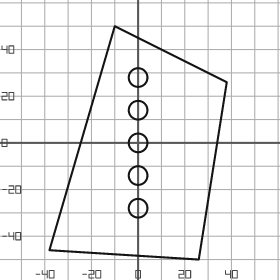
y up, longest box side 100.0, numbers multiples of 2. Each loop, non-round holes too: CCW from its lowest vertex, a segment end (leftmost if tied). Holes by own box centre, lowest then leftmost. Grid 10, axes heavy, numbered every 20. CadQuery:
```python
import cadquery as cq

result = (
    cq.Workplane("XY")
    .moveTo(26.0, -50.0)
    .lineTo(38.0, 26.0)
    .lineTo(-10.0, 50.0)
    .lineTo(-38.0, -46.0)
    .close()
    .moveTo(0.0, -28.0)
    .circle(4.0)
    .moveTo(0.0, -14.0)
    .circle(4.0)
    .moveTo(0.0, 0.0)
    .circle(4.0)
    .moveTo(0.0, 14.0)
    .circle(4.0)
    .moveTo(0.0, 28.0)
    .circle(4.0)
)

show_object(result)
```